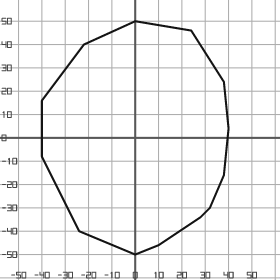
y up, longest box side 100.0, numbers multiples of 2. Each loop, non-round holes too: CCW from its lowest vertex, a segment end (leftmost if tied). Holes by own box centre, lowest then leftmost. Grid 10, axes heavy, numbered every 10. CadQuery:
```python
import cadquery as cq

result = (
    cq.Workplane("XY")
    .moveTo(0.0, -50.0)
    .lineTo(10.0, -46.0)
    .lineTo(28.0, -34.0)
    .lineTo(32.0, -30.0)
    .lineTo(38.0, -16.0)
    .lineTo(40.0, 4.0)
    .lineTo(38.0, 24.0)
    .lineTo(24.0, 46.0)
    .lineTo(0.0, 50.0)
    .lineTo(-22.0, 40.0)
    .lineTo(-40.0, 16.0)
    .lineTo(-40.0, -8.0)
    .lineTo(-24.0, -40.0)
    .close()
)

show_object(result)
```